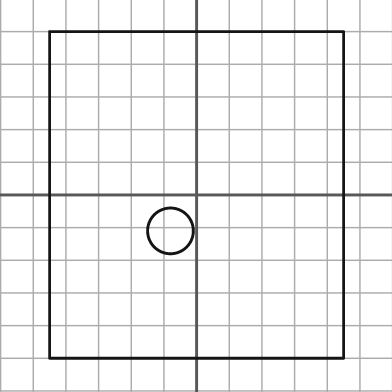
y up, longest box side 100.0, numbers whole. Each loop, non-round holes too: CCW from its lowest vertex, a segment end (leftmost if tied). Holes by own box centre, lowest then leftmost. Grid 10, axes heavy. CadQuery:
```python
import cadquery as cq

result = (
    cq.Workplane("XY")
    .moveTo(-45.0, -50.0)
    .lineTo(45.0, -50.0)
    .lineTo(45.0, 50.0)
    .lineTo(-45.0, 50.0)
    .close()
    .moveTo(-8.0, -11.0)
    .circle(7.0)
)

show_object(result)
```